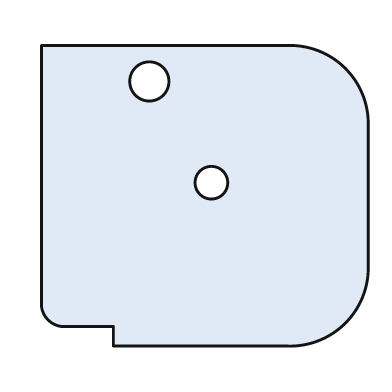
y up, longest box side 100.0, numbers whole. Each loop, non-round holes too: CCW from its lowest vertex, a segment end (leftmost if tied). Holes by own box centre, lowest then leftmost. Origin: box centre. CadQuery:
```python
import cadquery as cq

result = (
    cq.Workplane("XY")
    .moveTo(-28.0, -46.0)
    .lineTo(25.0, -46.0)
    .threePointArc((43.0, -39.0), (50.0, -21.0))
    .lineTo(50.0, 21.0)
    .threePointArc((43.0, 39.0), (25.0, 46.0))
    .lineTo(-50.0, 46.0)
    .lineTo(-50.0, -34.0)
    .threePointArc((-48.0, -38.0), (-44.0, -40.0))
    .lineTo(-28.0, -40.0)
    .close()
    .moveTo(2.0, 4.0)
    .circle(5.0)
    .moveTo(-17.0, 35.0)
    .circle(6.0)
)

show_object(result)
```